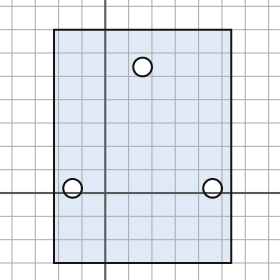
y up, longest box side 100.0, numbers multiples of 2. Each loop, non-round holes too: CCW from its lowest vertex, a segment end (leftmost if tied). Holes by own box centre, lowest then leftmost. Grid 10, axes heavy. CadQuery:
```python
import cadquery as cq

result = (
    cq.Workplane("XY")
    .moveTo(-22.0, -30.0)
    .lineTo(54.0, -30.0)
    .lineTo(54.0, 70.0)
    .lineTo(-22.0, 70.0)
    .close()
    .moveTo(-14.0, 2.0)
    .circle(4.0)
    .moveTo(46.0, 2.0)
    .circle(4.0)
    .moveTo(16.0, 54.0)
    .circle(4.0)
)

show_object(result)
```